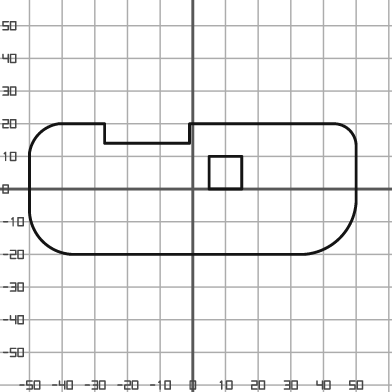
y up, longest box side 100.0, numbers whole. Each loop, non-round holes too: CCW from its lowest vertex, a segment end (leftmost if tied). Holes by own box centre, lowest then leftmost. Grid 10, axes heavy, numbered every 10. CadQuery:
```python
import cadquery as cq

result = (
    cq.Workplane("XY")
    .moveTo(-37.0, -20.0)
    .lineTo(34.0, -20.0)
    .threePointArc((45.0, -15.0), (50.0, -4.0))
    .lineTo(50.0, 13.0)
    .threePointArc((48.0, 18.0), (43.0, 20.0))
    .lineTo(-1.0, 20.0)
    .lineTo(-1.0, 14.0)
    .lineTo(-27.0, 14.0)
    .lineTo(-27.0, 20.0)
    .lineTo(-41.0, 20.0)
    .threePointArc((-47.0, 17.0), (-50.0, 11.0))
    .lineTo(-50.0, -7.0)
    .threePointArc((-46.0, -16.0), (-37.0, -20.0))
    .close()
    .moveTo(5.0, 0.0)
    .lineTo(15.0, 0.0)
    .lineTo(15.0, 10.0)
    .lineTo(5.0, 10.0)
    .close()
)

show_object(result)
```